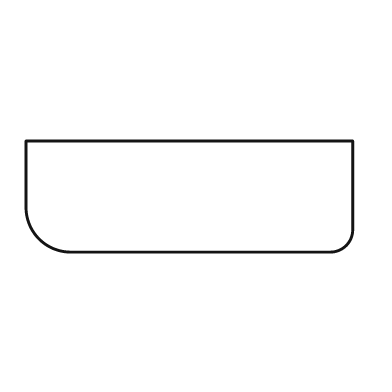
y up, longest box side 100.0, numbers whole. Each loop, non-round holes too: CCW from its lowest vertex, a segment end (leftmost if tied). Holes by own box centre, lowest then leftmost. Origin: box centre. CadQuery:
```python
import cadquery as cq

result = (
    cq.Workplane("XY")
    .moveTo(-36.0, -17.0)
    .lineTo(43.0, -17.0)
    .threePointArc((48.0, -15.0), (50.0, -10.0))
    .lineTo(50.0, 17.0)
    .lineTo(-50.0, 17.0)
    .lineTo(-50.0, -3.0)
    .threePointArc((-46.0, -13.0), (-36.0, -17.0))
    .close()
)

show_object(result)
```